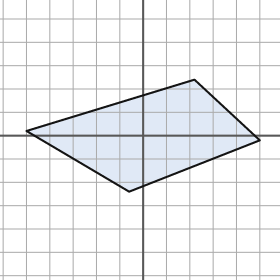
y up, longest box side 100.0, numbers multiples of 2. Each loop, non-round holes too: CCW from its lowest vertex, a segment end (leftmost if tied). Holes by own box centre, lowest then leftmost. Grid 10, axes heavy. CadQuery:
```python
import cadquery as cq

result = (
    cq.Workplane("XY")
    .moveTo(-6.0, -24.0)
    .lineTo(50.0, -2.0)
    .lineTo(22.0, 24.0)
    .lineTo(-50.0, 2.0)
    .close()
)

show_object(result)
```